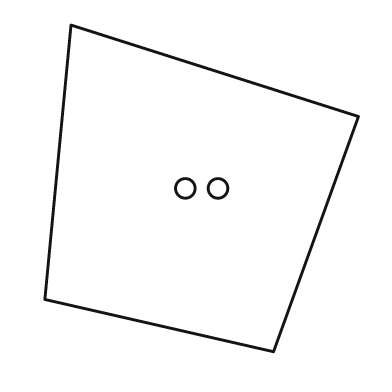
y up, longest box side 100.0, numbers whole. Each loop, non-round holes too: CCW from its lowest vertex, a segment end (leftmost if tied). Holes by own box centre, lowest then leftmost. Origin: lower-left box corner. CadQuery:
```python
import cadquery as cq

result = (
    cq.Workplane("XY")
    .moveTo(70.0, 0.0)
    .lineTo(96.0, 72.0)
    .lineTo(8.0, 100.0)
    .lineTo(0.0, 16.0)
    .close()
    .moveTo(43.0, 50.0)
    .circle(3.0)
    .moveTo(53.0, 50.0)
    .circle(3.0)
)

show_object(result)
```